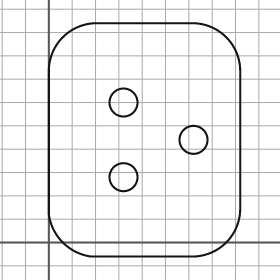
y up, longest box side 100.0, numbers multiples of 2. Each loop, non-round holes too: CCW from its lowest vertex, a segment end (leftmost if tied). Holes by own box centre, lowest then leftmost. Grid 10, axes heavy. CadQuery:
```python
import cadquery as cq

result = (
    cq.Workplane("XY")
    .moveTo(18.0, -6.0)
    .lineTo(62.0, -6.0)
    .threePointArc((76.0, 0.0), (82.0, 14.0))
    .lineTo(82.0, 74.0)
    .threePointArc((76.0, 88.0), (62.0, 94.0))
    .lineTo(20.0, 94.0)
    .threePointArc((6.0, 88.0), (0.0, 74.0))
    .lineTo(0.0, 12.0)
    .threePointArc((6.0, 0.0), (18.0, -6.0))
    .close()
    .moveTo(32.0, 28.0)
    .circle(6.0)
    .moveTo(62.0, 44.0)
    .circle(6.0)
    .moveTo(32.0, 60.0)
    .circle(6.0)
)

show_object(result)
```